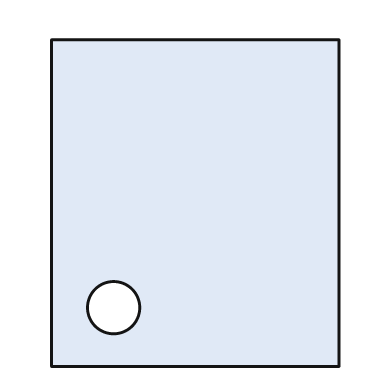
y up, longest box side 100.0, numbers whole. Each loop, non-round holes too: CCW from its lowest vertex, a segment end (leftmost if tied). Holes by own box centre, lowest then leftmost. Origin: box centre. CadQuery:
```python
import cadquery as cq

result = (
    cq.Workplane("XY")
    .moveTo(-44.0, -50.0)
    .lineTo(44.0, -50.0)
    .lineTo(44.0, 50.0)
    .lineTo(-44.0, 50.0)
    .close()
    .moveTo(-25.0, -32.0)
    .circle(8.0)
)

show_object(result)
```